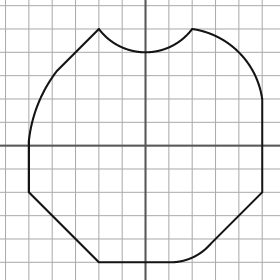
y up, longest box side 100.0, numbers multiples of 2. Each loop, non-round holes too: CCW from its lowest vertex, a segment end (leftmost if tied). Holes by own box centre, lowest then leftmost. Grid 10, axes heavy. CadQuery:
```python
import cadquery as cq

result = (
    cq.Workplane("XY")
    .moveTo(-20.0, -50.0)
    .lineTo(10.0, -50.0)
    .threePointArc((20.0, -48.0), (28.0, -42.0))
    .lineTo(50.0, -20.0)
    .lineTo(50.0, 20.0)
    .threePointArc((40.0, 40.0), (20.0, 50.0))
    .threePointArc((0.0, 40.0), (-20.0, 50.0))
    .lineTo(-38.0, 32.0)
    .threePointArc((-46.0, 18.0), (-50.0, 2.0))
    .lineTo(-50.0, -20.0)
    .close()
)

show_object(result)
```